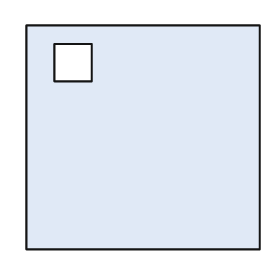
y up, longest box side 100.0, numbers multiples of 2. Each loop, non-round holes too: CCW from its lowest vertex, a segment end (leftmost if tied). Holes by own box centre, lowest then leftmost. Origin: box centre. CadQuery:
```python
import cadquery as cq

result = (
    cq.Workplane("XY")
    .moveTo(-50.0, -48.0)
    .lineTo(50.0, -48.0)
    .lineTo(50.0, 48.0)
    .lineTo(-50.0, 48.0)
    .close()
    .moveTo(-38.0, 24.0)
    .lineTo(-22.0, 24.0)
    .lineTo(-22.0, 40.0)
    .lineTo(-38.0, 40.0)
    .close()
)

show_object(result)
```